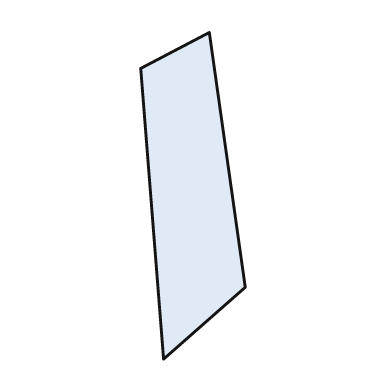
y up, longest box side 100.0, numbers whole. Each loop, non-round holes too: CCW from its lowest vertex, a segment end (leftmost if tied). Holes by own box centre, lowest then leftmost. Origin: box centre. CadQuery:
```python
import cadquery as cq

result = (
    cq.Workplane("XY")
    .moveTo(-9.0, -50.0)
    .lineTo(16.0, -28.0)
    .lineTo(5.0, 50.0)
    .lineTo(-16.0, 39.0)
    .close()
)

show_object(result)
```